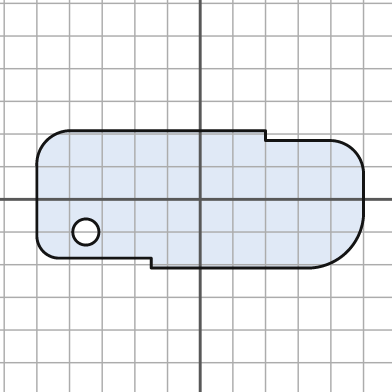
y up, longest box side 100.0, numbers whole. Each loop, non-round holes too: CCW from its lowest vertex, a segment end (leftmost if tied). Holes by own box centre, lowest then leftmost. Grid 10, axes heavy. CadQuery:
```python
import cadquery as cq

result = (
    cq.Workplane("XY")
    .moveTo(-15.0, -21.0)
    .lineTo(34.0, -21.0)
    .threePointArc((45.0, -16.0), (50.0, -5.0))
    .lineTo(50.0, 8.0)
    .threePointArc((47.0, 15.0), (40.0, 18.0))
    .lineTo(20.0, 18.0)
    .lineTo(20.0, 21.0)
    .lineTo(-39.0, 21.0)
    .threePointArc((-47.0, 18.0), (-50.0, 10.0))
    .lineTo(-50.0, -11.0)
    .threePointArc((-48.0, -16.0), (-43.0, -18.0))
    .lineTo(-15.0, -18.0)
    .close()
    .moveTo(-35.0, -10.0)
    .circle(4.0)
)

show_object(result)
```